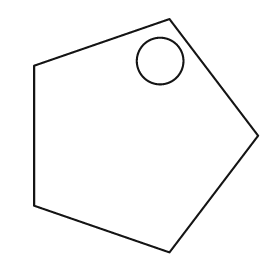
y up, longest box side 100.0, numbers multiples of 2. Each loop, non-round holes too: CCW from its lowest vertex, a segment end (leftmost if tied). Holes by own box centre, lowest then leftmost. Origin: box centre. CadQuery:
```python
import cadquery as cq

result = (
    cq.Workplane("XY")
    .moveTo(10.0, -50.0)
    .lineTo(48.0, 0.0)
    .lineTo(10.0, 50.0)
    .lineTo(-48.0, 30.0)
    .lineTo(-48.0, -30.0)
    .close()
    .moveTo(6.0, 32.0)
    .circle(10.0)
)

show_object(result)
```